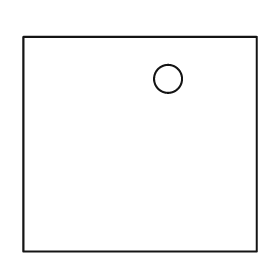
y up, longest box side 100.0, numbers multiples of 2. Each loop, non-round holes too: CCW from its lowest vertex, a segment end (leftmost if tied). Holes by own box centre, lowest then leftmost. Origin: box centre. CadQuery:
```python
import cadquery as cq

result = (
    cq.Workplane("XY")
    .moveTo(-50.0, -46.0)
    .lineTo(50.0, -46.0)
    .lineTo(50.0, 46.0)
    .lineTo(-50.0, 46.0)
    .close()
    .moveTo(12.0, 28.0)
    .circle(6.0)
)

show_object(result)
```